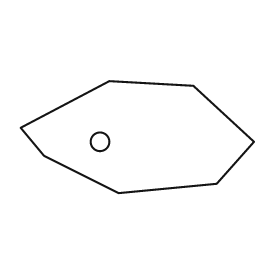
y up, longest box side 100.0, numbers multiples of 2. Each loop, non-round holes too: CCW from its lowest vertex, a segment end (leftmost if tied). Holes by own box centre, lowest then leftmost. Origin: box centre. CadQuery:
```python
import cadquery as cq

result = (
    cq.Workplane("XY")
    .moveTo(-8.0, -24.0)
    .lineTo(34.0, -20.0)
    .lineTo(50.0, -2.0)
    .lineTo(24.0, 22.0)
    .lineTo(-12.0, 24.0)
    .lineTo(-50.0, 4.0)
    .lineTo(-40.0, -8.0)
    .close()
    .moveTo(-16.0, -2.0)
    .circle(4.0)
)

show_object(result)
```